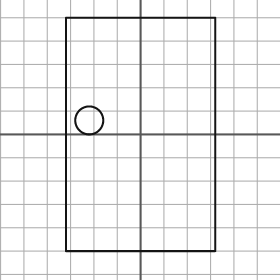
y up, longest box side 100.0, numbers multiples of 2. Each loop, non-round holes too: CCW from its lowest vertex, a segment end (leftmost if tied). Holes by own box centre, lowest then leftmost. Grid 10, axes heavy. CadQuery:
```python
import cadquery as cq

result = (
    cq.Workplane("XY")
    .moveTo(-32.0, -50.0)
    .lineTo(32.0, -50.0)
    .lineTo(32.0, 50.0)
    .lineTo(-32.0, 50.0)
    .close()
    .moveTo(-22.0, 6.0)
    .circle(6.0)
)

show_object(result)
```